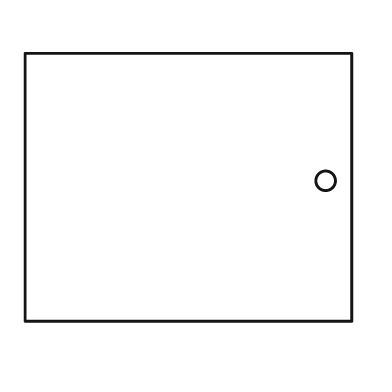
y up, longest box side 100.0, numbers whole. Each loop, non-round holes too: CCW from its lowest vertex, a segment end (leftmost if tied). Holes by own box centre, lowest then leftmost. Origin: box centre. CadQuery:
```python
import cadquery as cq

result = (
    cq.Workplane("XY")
    .moveTo(-50.0, -41.0)
    .lineTo(50.0, -41.0)
    .lineTo(50.0, 41.0)
    .lineTo(-50.0, 41.0)
    .close()
    .moveTo(42.0, 2.0)
    .circle(3.0)
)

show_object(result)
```